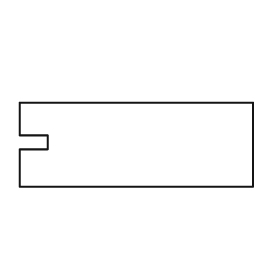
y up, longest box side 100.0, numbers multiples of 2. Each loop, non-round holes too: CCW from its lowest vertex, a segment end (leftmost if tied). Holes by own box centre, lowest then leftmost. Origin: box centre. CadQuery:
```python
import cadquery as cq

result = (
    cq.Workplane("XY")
    .moveTo(-50.0, -18.0)
    .lineTo(50.0, -18.0)
    .lineTo(50.0, 18.0)
    .lineTo(-50.0, 18.0)
    .lineTo(-50.0, 4.0)
    .lineTo(-38.0, 4.0)
    .lineTo(-38.0, -2.0)
    .lineTo(-50.0, -2.0)
    .close()
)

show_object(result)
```